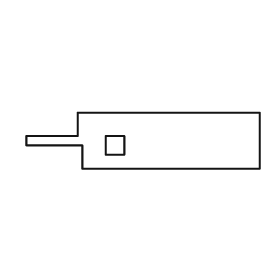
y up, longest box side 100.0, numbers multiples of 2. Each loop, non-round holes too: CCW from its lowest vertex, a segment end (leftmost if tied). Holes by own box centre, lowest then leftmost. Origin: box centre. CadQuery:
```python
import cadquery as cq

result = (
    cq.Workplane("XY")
    .moveTo(-26.0, -12.0)
    .lineTo(50.0, -12.0)
    .lineTo(50.0, 12.0)
    .lineTo(-28.0, 12.0)
    .lineTo(-28.0, 2.0)
    .lineTo(-50.0, 2.0)
    .lineTo(-50.0, -2.0)
    .lineTo(-26.0, -2.0)
    .close()
    .moveTo(-16.0, -6.0)
    .lineTo(-8.0, -6.0)
    .lineTo(-8.0, 2.0)
    .lineTo(-16.0, 2.0)
    .close()
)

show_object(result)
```